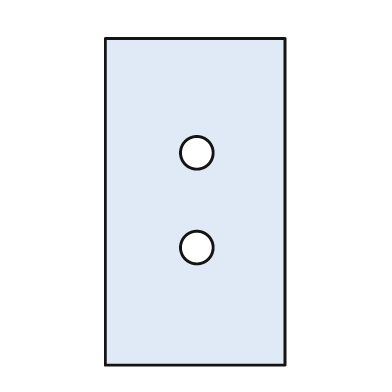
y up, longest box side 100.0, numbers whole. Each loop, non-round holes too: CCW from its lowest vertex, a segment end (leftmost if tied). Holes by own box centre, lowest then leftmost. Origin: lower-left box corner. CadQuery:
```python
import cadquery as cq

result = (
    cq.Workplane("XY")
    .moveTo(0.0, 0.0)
    .lineTo(55.0, 0.0)
    .lineTo(55.0, 100.0)
    .lineTo(0.0, 100.0)
    .close()
    .moveTo(28.0, 36.0)
    .circle(5.0)
    .moveTo(28.0, 65.0)
    .circle(5.0)
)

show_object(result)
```